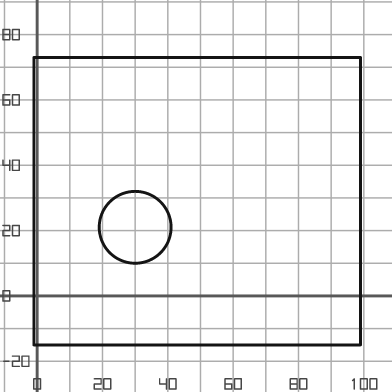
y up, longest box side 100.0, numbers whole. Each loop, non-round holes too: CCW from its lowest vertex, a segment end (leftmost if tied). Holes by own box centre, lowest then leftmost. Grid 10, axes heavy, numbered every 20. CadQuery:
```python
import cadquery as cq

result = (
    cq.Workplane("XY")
    .moveTo(-1.0, -15.0)
    .lineTo(99.0, -15.0)
    .lineTo(99.0, 73.0)
    .lineTo(-1.0, 73.0)
    .close()
    .moveTo(30.0, 21.0)
    .circle(11.0)
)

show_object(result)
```